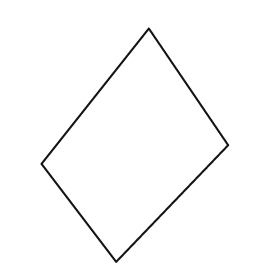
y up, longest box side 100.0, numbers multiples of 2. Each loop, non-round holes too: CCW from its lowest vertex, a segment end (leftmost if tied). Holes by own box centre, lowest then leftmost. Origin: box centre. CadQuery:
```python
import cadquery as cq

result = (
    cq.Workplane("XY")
    .moveTo(-8.0, -50.0)
    .lineTo(40.0, 0.0)
    .lineTo(6.0, 50.0)
    .lineTo(-40.0, -8.0)
    .close()
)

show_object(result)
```